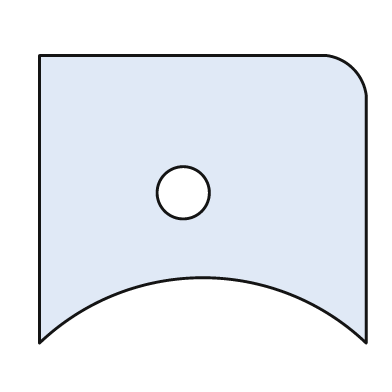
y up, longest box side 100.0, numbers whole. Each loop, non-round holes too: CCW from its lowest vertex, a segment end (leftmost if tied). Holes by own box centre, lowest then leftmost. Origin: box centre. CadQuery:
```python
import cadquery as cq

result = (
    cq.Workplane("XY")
    .moveTo(-50.0, -44.0)
    .threePointArc((0.0, -24.0), (50.0, -44.0))
    .lineTo(50.0, 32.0)
    .threePointArc((46.0, 40.0), (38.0, 44.0))
    .lineTo(-50.0, 44.0)
    .close()
    .moveTo(-6.0, 2.0)
    .circle(8.0)
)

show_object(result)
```